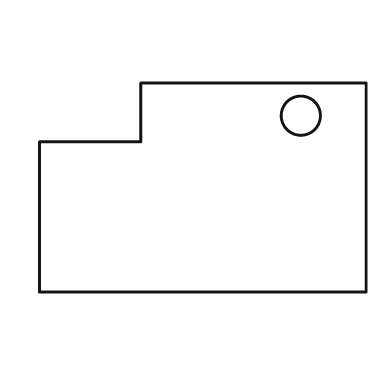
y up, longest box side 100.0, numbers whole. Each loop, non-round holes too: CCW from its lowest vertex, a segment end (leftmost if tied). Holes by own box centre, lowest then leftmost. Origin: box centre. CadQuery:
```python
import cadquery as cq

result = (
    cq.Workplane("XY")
    .moveTo(-50.0, -32.0)
    .lineTo(50.0, -32.0)
    .lineTo(50.0, 32.0)
    .lineTo(-19.0, 32.0)
    .lineTo(-19.0, 14.0)
    .lineTo(-50.0, 14.0)
    .close()
    .moveTo(30.0, 22.0)
    .circle(6.0)
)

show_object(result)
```